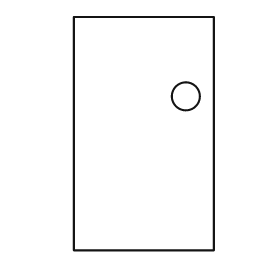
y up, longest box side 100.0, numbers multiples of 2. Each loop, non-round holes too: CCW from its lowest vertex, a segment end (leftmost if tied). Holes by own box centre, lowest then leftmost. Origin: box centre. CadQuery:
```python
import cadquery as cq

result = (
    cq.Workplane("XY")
    .moveTo(-30.0, -50.0)
    .lineTo(30.0, -50.0)
    .lineTo(30.0, 50.0)
    .lineTo(-30.0, 50.0)
    .close()
    .moveTo(18.0, 16.0)
    .circle(6.0)
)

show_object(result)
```